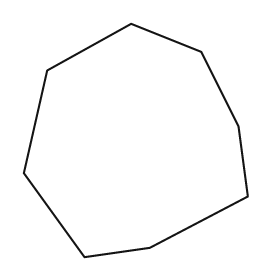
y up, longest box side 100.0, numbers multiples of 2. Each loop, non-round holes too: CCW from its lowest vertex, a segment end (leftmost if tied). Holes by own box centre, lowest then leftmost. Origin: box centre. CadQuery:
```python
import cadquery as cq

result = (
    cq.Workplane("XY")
    .moveTo(-22.0, -50.0)
    .lineTo(6.0, -46.0)
    .lineTo(48.0, -24.0)
    .lineTo(44.0, 6.0)
    .lineTo(28.0, 38.0)
    .lineTo(-2.0, 50.0)
    .lineTo(-38.0, 30.0)
    .lineTo(-48.0, -14.0)
    .close()
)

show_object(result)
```